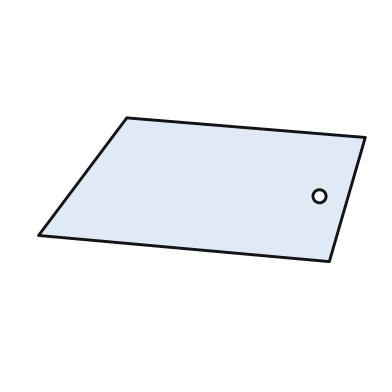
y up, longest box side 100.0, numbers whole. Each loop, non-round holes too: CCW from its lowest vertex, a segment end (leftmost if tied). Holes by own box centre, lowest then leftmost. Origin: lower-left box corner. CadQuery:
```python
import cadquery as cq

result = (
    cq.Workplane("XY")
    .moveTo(89.0, 0.0)
    .lineTo(100.0, 38.0)
    .lineTo(27.0, 44.0)
    .lineTo(0.0, 8.0)
    .close()
    .moveTo(86.0, 20.0)
    .circle(2.0)
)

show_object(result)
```